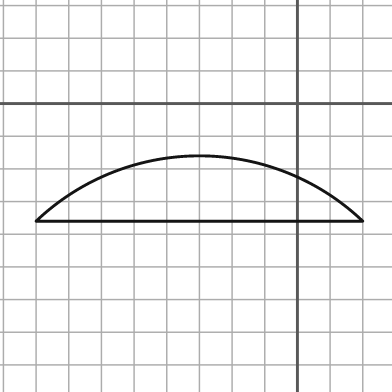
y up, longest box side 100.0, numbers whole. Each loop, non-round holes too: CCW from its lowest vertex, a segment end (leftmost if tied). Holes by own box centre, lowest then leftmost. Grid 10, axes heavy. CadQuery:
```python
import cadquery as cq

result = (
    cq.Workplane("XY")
    .moveTo(-80.0, -36.0)
    .lineTo(20.0, -36.0)
    .threePointArc((-30.0, -16.0), (-80.0, -36.0))
    .close()
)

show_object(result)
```